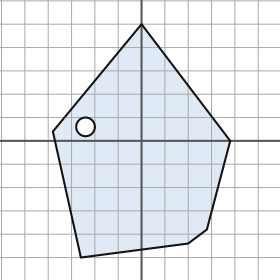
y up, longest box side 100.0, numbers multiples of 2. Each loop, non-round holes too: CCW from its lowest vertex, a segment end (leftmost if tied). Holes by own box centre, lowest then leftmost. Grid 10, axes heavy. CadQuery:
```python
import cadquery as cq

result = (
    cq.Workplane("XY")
    .moveTo(-26.0, -50.0)
    .lineTo(20.0, -44.0)
    .lineTo(28.0, -38.0)
    .lineTo(38.0, 0.0)
    .lineTo(0.0, 50.0)
    .lineTo(-38.0, 4.0)
    .close()
    .moveTo(-24.0, 6.0)
    .circle(4.0)
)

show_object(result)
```